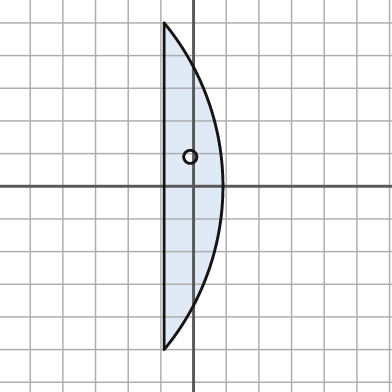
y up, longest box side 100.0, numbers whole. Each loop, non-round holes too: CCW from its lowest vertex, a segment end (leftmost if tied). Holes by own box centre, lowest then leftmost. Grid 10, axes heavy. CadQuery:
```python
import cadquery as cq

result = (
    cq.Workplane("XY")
    .moveTo(-9.0, -50.0)
    .threePointArc((9.0, 0.0), (-9.0, 50.0))
    .close()
    .moveTo(-1.0, 9.0)
    .circle(2.0)
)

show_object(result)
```